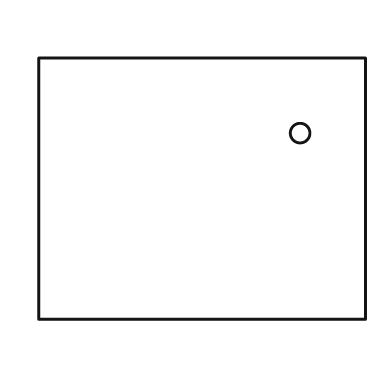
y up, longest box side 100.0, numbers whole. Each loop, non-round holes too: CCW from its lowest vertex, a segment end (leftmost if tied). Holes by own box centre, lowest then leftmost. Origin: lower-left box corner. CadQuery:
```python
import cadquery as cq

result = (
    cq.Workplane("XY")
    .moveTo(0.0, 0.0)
    .lineTo(100.0, 0.0)
    .lineTo(100.0, 80.0)
    .lineTo(0.0, 80.0)
    .close()
    .moveTo(80.0, 57.0)
    .circle(3.0)
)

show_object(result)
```